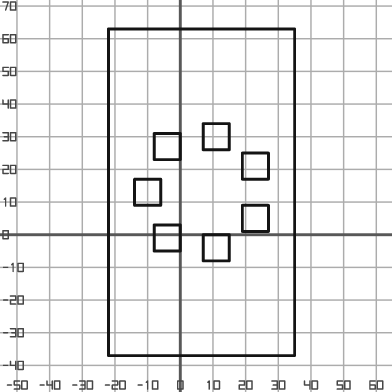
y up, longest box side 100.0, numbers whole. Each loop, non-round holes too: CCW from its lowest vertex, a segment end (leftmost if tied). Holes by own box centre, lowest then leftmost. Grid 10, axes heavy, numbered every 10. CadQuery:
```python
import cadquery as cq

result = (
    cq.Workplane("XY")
    .moveTo(-22.0, -37.0)
    .lineTo(35.0, -37.0)
    .lineTo(35.0, 63.0)
    .lineTo(-22.0, 63.0)
    .close()
    .moveTo(7.0, -8.0)
    .lineTo(15.0, -8.0)
    .lineTo(15.0, 0.0)
    .lineTo(7.0, 0.0)
    .close()
    .moveTo(-8.0, -5.0)
    .lineTo(0.0, -5.0)
    .lineTo(0.0, 3.0)
    .lineTo(-8.0, 3.0)
    .close()
    .moveTo(19.0, 1.0)
    .lineTo(27.0, 1.0)
    .lineTo(27.0, 9.0)
    .lineTo(19.0, 9.0)
    .close()
    .moveTo(-14.0, 9.0)
    .lineTo(-6.0, 9.0)
    .lineTo(-6.0, 17.0)
    .lineTo(-14.0, 17.0)
    .close()
    .moveTo(19.0, 17.0)
    .lineTo(27.0, 17.0)
    .lineTo(27.0, 25.0)
    .lineTo(19.0, 25.0)
    .close()
    .moveTo(-8.0, 23.0)
    .lineTo(0.0, 23.0)
    .lineTo(0.0, 31.0)
    .lineTo(-8.0, 31.0)
    .close()
    .moveTo(7.0, 26.0)
    .lineTo(15.0, 26.0)
    .lineTo(15.0, 34.0)
    .lineTo(7.0, 34.0)
    .close()
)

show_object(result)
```